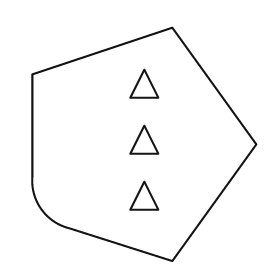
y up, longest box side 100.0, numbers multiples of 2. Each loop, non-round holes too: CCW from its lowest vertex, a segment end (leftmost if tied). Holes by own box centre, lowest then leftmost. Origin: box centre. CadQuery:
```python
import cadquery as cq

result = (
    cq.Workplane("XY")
    .moveTo(12.0, -50.0)
    .lineTo(48.0, 0.0)
    .lineTo(12.0, 50.0)
    .lineTo(-48.0, 30.0)
    .lineTo(-48.0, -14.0)
    .threePointArc((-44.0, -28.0), (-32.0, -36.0))
    .close()
    .moveTo(-6.0, -28.0)
    .lineTo(6.0, -28.0)
    .lineTo(0.0, -16.0)
    .close()
    .moveTo(-6.0, -4.0)
    .lineTo(6.0, -4.0)
    .lineTo(0.0, 8.0)
    .close()
    .moveTo(-6.0, 20.0)
    .lineTo(6.0, 20.0)
    .lineTo(0.0, 32.0)
    .close()
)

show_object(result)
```